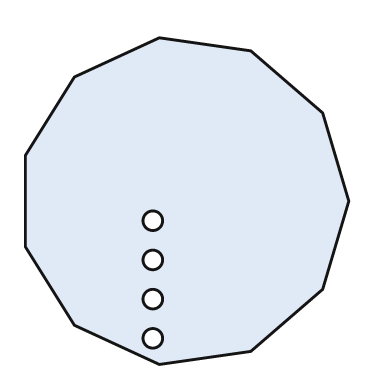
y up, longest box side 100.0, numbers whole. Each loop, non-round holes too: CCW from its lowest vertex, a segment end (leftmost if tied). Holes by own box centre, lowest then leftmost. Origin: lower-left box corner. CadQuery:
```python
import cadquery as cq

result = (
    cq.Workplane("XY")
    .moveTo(41.0, 0.0)
    .lineTo(69.0, 4.0)
    .lineTo(91.0, 23.0)
    .lineTo(99.0, 50.0)
    .lineTo(91.0, 77.0)
    .lineTo(69.0, 96.0)
    .lineTo(41.0, 100.0)
    .lineTo(15.0, 88.0)
    .lineTo(0.0, 64.0)
    .lineTo(0.0, 36.0)
    .lineTo(15.0, 12.0)
    .close()
    .moveTo(39.0, 8.0)
    .circle(3.0)
    .moveTo(39.0, 20.0)
    .circle(3.0)
    .moveTo(39.0, 32.0)
    .circle(3.0)
    .moveTo(39.0, 44.0)
    .circle(3.0)
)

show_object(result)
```